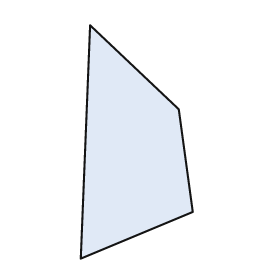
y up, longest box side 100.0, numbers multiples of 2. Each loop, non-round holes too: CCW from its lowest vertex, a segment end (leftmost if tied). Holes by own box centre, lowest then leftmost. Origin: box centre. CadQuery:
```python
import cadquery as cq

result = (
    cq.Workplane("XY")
    .moveTo(-24.0, -50.0)
    .lineTo(24.0, -30.0)
    .lineTo(18.0, 14.0)
    .lineTo(-20.0, 50.0)
    .close()
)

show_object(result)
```